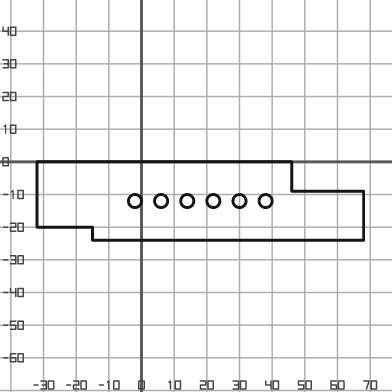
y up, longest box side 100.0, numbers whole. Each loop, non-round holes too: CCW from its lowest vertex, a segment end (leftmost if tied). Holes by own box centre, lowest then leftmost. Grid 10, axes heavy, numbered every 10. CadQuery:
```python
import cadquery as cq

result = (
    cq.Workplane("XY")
    .moveTo(-15.0, -24.0)
    .lineTo(68.0, -24.0)
    .lineTo(68.0, -9.0)
    .lineTo(46.0, -9.0)
    .lineTo(46.0, 0.0)
    .lineTo(-32.0, 0.0)
    .lineTo(-32.0, -20.0)
    .lineTo(-15.0, -20.0)
    .close()
    .moveTo(-2.0, -12.0)
    .circle(2.0)
    .moveTo(6.0, -12.0)
    .circle(2.0)
    .moveTo(14.0, -12.0)
    .circle(2.0)
    .moveTo(22.0, -12.0)
    .circle(2.0)
    .moveTo(30.0, -12.0)
    .circle(2.0)
    .moveTo(38.0, -12.0)
    .circle(2.0)
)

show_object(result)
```